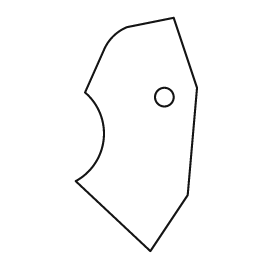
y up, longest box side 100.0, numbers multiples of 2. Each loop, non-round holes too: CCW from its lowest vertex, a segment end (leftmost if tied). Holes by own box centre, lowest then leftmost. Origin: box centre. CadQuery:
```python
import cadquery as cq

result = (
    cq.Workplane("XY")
    .moveTo(6.0, -50.0)
    .lineTo(22.0, -26.0)
    .lineTo(26.0, 20.0)
    .lineTo(16.0, 50.0)
    .lineTo(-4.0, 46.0)
    .threePointArc((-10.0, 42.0), (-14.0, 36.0))
    .lineTo(-22.0, 18.0)
    .threePointArc((-14.0, -2.0), (-26.0, -20.0))
    .close()
    .moveTo(12.0, 16.0)
    .circle(4.0)
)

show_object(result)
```